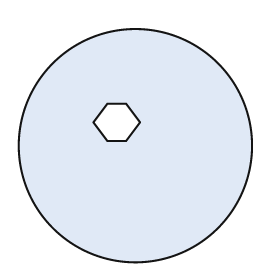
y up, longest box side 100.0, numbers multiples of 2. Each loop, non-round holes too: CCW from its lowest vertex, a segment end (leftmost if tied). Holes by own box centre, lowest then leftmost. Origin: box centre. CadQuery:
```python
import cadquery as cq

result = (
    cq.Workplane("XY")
    .moveTo(0.0, 0.0)
    .circle(50.0)
    .moveTo(-12.0, 2.0)
    .lineTo(-4.0, 2.0)
    .lineTo(2.0, 10.0)
    .lineTo(-4.0, 18.0)
    .lineTo(-12.0, 18.0)
    .lineTo(-18.0, 10.0)
    .close()
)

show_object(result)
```